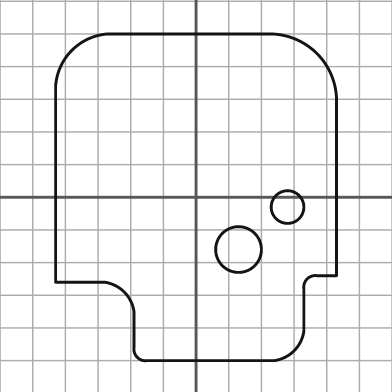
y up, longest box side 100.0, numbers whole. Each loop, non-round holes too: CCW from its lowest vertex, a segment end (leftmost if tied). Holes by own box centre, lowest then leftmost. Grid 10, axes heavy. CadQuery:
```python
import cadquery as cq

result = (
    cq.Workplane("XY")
    .moveTo(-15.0, -50.0)
    .lineTo(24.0, -50.0)
    .threePointArc((30.0, -47.0), (33.0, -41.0))
    .lineTo(33.0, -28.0)
    .threePointArc((34.0, -25.0), (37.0, -24.0))
    .lineTo(43.0, -24.0)
    .lineTo(43.0, 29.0)
    .threePointArc((37.0, 44.0), (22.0, 50.0))
    .lineTo(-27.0, 50.0)
    .threePointArc((-38.0, 45.0), (-43.0, 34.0))
    .lineTo(-43.0, -26.0)
    .lineTo(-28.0, -26.0)
    .threePointArc((-22.0, -29.0), (-19.0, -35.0))
    .lineTo(-19.0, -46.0)
    .threePointArc((-18.0, -49.0), (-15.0, -50.0))
    .close()
    .moveTo(13.0, -16.0)
    .circle(7.0)
    .moveTo(28.0, -3.0)
    .circle(5.0)
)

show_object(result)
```